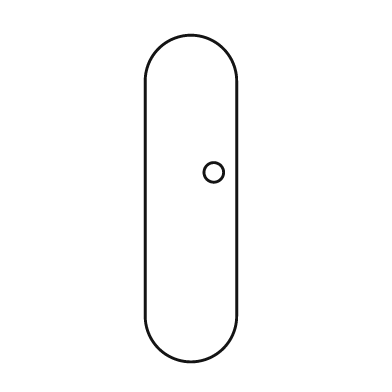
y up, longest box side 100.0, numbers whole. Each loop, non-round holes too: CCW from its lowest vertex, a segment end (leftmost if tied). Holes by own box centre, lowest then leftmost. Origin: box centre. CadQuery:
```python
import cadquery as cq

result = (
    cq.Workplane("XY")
    .moveTo(-14.0, -36.0)
    .threePointArc((0.0, -50.0), (14.0, -36.0))
    .lineTo(14.0, 36.0)
    .threePointArc((0.0, 50.0), (-14.0, 36.0))
    .close()
    .moveTo(7.0, 8.0)
    .circle(3.0)
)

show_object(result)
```